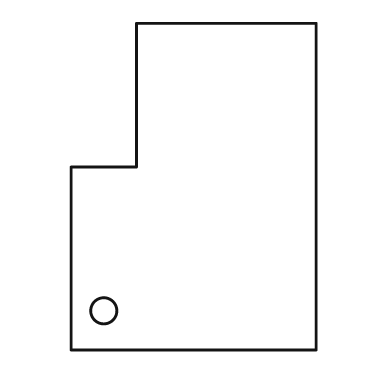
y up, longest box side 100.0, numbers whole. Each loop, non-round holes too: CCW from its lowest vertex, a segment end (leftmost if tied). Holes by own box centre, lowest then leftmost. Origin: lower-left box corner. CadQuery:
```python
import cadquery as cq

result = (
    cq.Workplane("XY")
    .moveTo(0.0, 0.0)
    .lineTo(75.0, 0.0)
    .lineTo(75.0, 100.0)
    .lineTo(20.0, 100.0)
    .lineTo(20.0, 56.0)
    .lineTo(0.0, 56.0)
    .close()
    .moveTo(10.0, 12.0)
    .circle(4.0)
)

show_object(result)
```